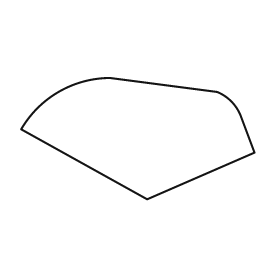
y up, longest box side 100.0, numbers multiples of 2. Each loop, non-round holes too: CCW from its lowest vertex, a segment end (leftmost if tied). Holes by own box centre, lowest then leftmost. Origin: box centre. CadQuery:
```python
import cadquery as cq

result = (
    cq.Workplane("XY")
    .moveTo(4.0, -26.0)
    .lineTo(50.0, -6.0)
    .lineTo(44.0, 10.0)
    .threePointArc((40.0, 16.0), (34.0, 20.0))
    .lineTo(-12.0, 26.0)
    .threePointArc((-34.0, 20.0), (-50.0, 4.0))
    .close()
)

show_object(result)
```